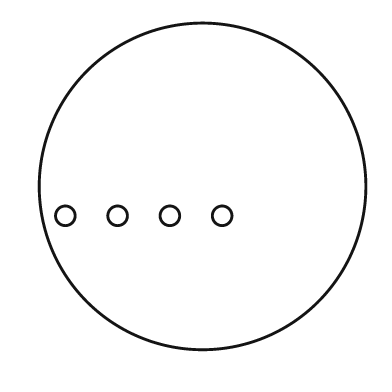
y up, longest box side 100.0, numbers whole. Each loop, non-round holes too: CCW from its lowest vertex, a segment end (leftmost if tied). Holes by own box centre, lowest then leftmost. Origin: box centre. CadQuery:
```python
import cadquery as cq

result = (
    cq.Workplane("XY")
    .moveTo(0.0, 0.0)
    .circle(50.0)
    .moveTo(-42.0, -9.0)
    .circle(3.0)
    .moveTo(-26.0, -9.0)
    .circle(3.0)
    .moveTo(-10.0, -9.0)
    .circle(3.0)
    .moveTo(6.0, -9.0)
    .circle(3.0)
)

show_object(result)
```